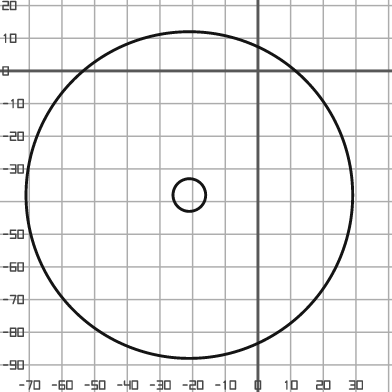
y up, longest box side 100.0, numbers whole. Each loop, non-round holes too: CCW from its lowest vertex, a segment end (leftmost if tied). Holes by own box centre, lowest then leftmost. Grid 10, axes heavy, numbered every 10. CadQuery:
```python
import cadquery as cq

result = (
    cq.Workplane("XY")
    .moveTo(-21.0, -38.0)
    .circle(50.0)
    .moveTo(-21.0, -38.0)
    .circle(5.0)
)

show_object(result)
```